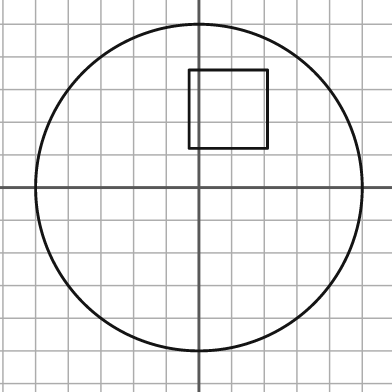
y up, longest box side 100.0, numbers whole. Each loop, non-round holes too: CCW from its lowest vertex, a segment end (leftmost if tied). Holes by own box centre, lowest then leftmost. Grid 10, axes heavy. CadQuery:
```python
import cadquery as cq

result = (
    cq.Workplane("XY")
    .moveTo(0.0, 0.0)
    .circle(50.0)
    .moveTo(-3.0, 12.0)
    .lineTo(21.0, 12.0)
    .lineTo(21.0, 36.0)
    .lineTo(-3.0, 36.0)
    .close()
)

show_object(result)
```